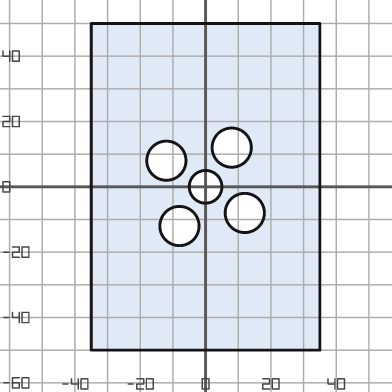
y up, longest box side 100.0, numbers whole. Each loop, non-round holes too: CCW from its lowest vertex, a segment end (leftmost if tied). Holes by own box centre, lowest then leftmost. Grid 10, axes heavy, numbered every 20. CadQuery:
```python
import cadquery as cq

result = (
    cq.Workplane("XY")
    .moveTo(-35.0, -50.0)
    .lineTo(35.0, -50.0)
    .lineTo(35.0, 50.0)
    .lineTo(-35.0, 50.0)
    .close()
    .moveTo(-8.0, -12.0)
    .circle(6.0)
    .moveTo(12.0, -8.0)
    .circle(6.0)
    .moveTo(0.0, 0.0)
    .circle(5.0)
    .moveTo(-12.0, 8.0)
    .circle(6.0)
    .moveTo(8.0, 12.0)
    .circle(6.0)
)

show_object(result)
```